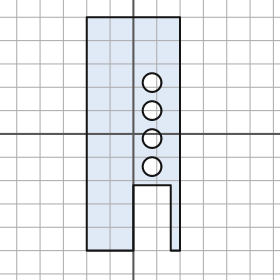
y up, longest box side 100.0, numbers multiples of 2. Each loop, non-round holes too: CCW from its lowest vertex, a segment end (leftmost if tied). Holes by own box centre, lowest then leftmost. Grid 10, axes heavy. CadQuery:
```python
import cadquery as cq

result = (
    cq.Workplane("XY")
    .moveTo(-20.0, -50.0)
    .lineTo(0.0, -50.0)
    .lineTo(0.0, -22.0)
    .lineTo(16.0, -22.0)
    .lineTo(16.0, -50.0)
    .lineTo(20.0, -50.0)
    .lineTo(20.0, 50.0)
    .lineTo(-20.0, 50.0)
    .close()
    .moveTo(8.0, -14.0)
    .circle(4.0)
    .moveTo(8.0, -2.0)
    .circle(4.0)
    .moveTo(8.0, 10.0)
    .circle(4.0)
    .moveTo(8.0, 22.0)
    .circle(4.0)
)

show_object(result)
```